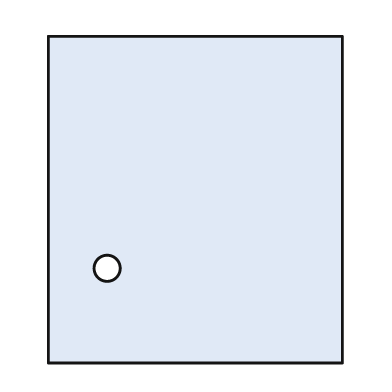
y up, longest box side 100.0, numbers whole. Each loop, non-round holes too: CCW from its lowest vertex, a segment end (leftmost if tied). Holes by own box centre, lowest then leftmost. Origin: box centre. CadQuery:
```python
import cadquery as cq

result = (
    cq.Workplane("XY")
    .moveTo(-45.0, -50.0)
    .lineTo(45.0, -50.0)
    .lineTo(45.0, 50.0)
    .lineTo(-45.0, 50.0)
    .close()
    .moveTo(-27.0, -21.0)
    .circle(4.0)
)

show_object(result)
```